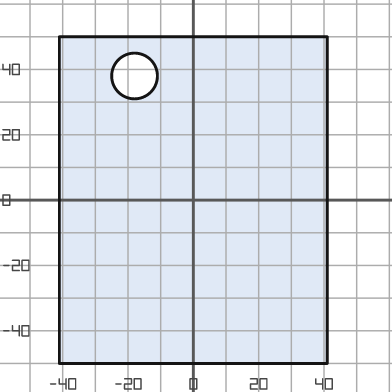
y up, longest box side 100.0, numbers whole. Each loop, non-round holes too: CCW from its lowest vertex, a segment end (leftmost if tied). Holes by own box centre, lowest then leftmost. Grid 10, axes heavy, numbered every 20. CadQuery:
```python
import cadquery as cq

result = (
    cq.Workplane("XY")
    .moveTo(-41.0, -50.0)
    .lineTo(41.0, -50.0)
    .lineTo(41.0, 50.0)
    .lineTo(-41.0, 50.0)
    .close()
    .moveTo(-18.0, 38.0)
    .circle(7.0)
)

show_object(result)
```